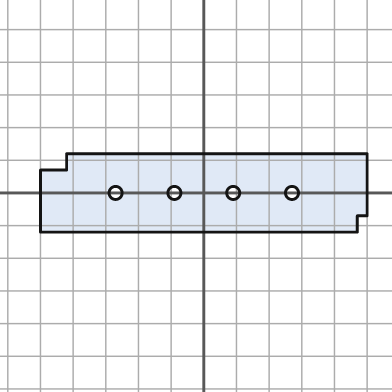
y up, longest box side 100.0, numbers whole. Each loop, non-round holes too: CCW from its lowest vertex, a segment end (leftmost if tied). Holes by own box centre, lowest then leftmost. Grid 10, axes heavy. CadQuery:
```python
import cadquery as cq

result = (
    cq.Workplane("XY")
    .moveTo(-50.0, -12.0)
    .lineTo(47.0, -12.0)
    .lineTo(47.0, -7.0)
    .lineTo(50.0, -7.0)
    .lineTo(50.0, 12.0)
    .lineTo(-42.0, 12.0)
    .lineTo(-42.0, 7.0)
    .lineTo(-50.0, 7.0)
    .close()
    .moveTo(-27.0, 0.0)
    .circle(2.0)
    .moveTo(-9.0, 0.0)
    .circle(2.0)
    .moveTo(9.0, 0.0)
    .circle(2.0)
    .moveTo(27.0, 0.0)
    .circle(2.0)
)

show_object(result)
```